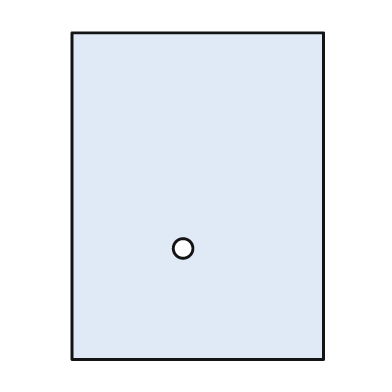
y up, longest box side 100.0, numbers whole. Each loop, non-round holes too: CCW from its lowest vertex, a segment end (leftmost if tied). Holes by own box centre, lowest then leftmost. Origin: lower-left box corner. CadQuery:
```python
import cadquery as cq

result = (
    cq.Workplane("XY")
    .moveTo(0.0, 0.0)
    .lineTo(77.0, 0.0)
    .lineTo(77.0, 100.0)
    .lineTo(0.0, 100.0)
    .close()
    .moveTo(34.0, 34.0)
    .circle(3.0)
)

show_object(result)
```